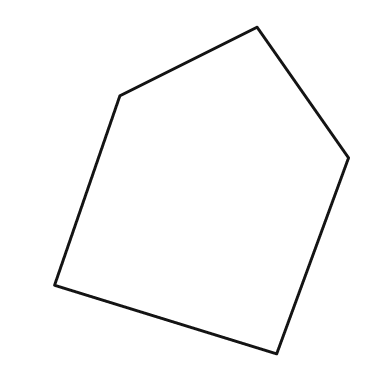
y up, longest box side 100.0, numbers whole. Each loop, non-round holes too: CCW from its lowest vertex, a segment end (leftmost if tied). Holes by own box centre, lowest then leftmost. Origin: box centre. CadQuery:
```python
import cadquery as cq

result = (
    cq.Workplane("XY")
    .moveTo(23.0, -50.0)
    .lineTo(45.0, 10.0)
    .lineTo(17.0, 50.0)
    .lineTo(-25.0, 29.0)
    .lineTo(-45.0, -29.0)
    .close()
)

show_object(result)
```